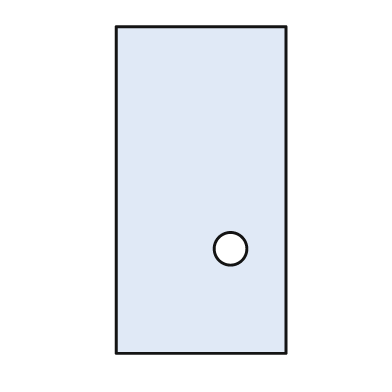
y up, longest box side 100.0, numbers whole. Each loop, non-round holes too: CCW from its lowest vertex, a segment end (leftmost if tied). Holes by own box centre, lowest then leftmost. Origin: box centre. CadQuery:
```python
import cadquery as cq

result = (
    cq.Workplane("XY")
    .moveTo(-26.0, -50.0)
    .lineTo(26.0, -50.0)
    .lineTo(26.0, 50.0)
    .lineTo(-26.0, 50.0)
    .close()
    .moveTo(9.0, -18.0)
    .circle(5.0)
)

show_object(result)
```